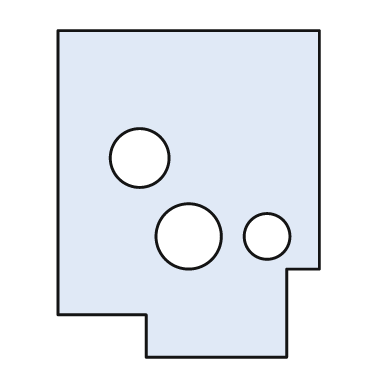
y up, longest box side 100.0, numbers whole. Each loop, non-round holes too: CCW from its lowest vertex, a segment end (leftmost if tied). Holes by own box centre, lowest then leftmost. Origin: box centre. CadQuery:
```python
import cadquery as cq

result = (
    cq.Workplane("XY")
    .moveTo(-13.0, -50.0)
    .lineTo(30.0, -50.0)
    .lineTo(30.0, -23.0)
    .lineTo(40.0, -23.0)
    .lineTo(40.0, 50.0)
    .lineTo(-40.0, 50.0)
    .lineTo(-40.0, -37.0)
    .lineTo(-13.0, -37.0)
    .close()
    .moveTo(0.0, -13.0)
    .circle(10.0)
    .moveTo(24.0, -13.0)
    .circle(7.0)
    .moveTo(-15.0, 11.0)
    .circle(9.0)
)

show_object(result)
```